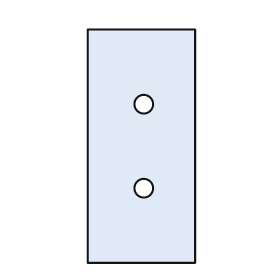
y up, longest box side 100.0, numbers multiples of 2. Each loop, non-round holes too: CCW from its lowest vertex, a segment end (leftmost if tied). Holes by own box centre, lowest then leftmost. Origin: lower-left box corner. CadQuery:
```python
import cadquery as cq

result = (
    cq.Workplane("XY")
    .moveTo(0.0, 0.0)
    .lineTo(46.0, 0.0)
    .lineTo(46.0, 100.0)
    .lineTo(0.0, 100.0)
    .close()
    .moveTo(24.0, 32.0)
    .circle(4.0)
    .moveTo(24.0, 68.0)
    .circle(4.0)
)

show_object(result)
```